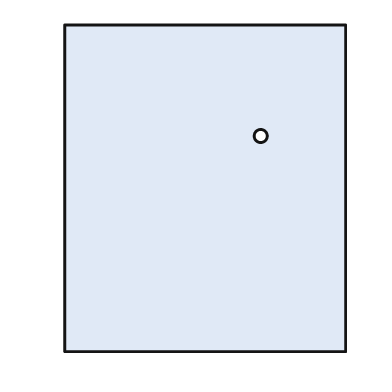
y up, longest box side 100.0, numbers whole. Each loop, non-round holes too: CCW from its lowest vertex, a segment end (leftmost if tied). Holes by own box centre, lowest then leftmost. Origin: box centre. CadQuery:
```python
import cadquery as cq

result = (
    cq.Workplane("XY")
    .moveTo(-43.0, -50.0)
    .lineTo(43.0, -50.0)
    .lineTo(43.0, 50.0)
    .lineTo(-43.0, 50.0)
    .close()
    .moveTo(17.0, 16.0)
    .circle(2.0)
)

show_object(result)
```